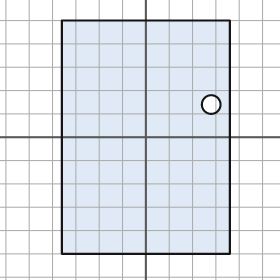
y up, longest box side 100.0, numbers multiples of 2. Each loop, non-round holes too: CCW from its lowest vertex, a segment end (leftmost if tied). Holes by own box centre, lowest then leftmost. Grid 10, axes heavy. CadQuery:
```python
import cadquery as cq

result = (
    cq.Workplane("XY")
    .moveTo(-36.0, -50.0)
    .lineTo(36.0, -50.0)
    .lineTo(36.0, 50.0)
    .lineTo(-36.0, 50.0)
    .close()
    .moveTo(28.0, 14.0)
    .circle(4.0)
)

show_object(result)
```